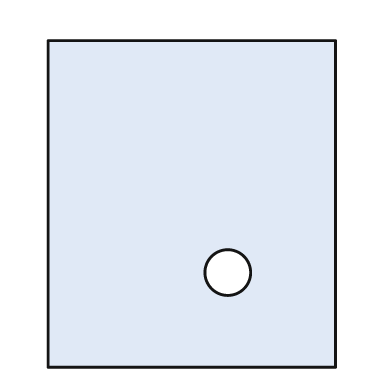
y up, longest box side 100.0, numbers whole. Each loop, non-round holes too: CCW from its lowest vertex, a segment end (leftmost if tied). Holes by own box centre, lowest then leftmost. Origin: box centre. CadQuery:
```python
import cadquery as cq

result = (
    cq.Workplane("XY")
    .moveTo(-44.0, -50.0)
    .lineTo(44.0, -50.0)
    .lineTo(44.0, 50.0)
    .lineTo(-44.0, 50.0)
    .close()
    .moveTo(11.0, -21.0)
    .circle(7.0)
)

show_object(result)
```